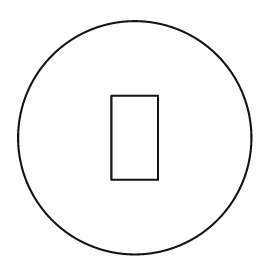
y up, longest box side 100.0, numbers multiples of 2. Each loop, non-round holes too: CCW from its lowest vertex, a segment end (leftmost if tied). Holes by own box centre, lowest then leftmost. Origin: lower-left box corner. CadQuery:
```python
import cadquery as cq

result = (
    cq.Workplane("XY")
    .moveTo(50.0, 50.0)
    .circle(50.0)
    .moveTo(40.0, 32.0)
    .lineTo(60.0, 32.0)
    .lineTo(60.0, 68.0)
    .lineTo(40.0, 68.0)
    .close()
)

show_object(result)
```